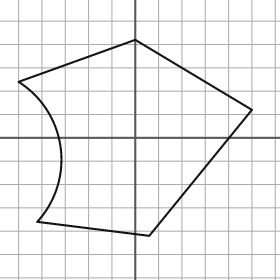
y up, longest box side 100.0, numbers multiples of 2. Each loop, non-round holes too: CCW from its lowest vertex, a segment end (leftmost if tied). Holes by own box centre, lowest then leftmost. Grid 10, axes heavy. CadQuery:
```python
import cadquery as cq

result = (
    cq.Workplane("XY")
    .moveTo(6.0, -42.0)
    .lineTo(50.0, 12.0)
    .lineTo(0.0, 42.0)
    .lineTo(-50.0, 24.0)
    .threePointArc((-32.0, -4.0), (-42.0, -36.0))
    .close()
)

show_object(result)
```